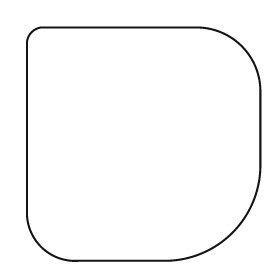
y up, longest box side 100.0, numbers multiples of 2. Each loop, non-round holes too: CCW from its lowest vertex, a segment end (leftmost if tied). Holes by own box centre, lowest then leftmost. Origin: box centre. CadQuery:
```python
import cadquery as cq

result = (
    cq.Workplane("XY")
    .moveTo(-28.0, -50.0)
    .lineTo(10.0, -50.0)
    .threePointArc((38.0, -38.0), (50.0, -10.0))
    .lineTo(50.0, 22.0)
    .threePointArc((42.0, 42.0), (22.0, 50.0))
    .lineTo(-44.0, 50.0)
    .threePointArc((-48.0, 48.0), (-50.0, 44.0))
    .lineTo(-50.0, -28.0)
    .threePointArc((-44.0, -44.0), (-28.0, -50.0))
    .close()
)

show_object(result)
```